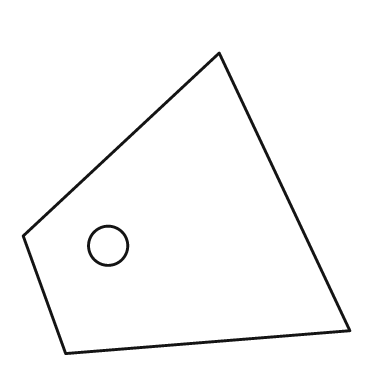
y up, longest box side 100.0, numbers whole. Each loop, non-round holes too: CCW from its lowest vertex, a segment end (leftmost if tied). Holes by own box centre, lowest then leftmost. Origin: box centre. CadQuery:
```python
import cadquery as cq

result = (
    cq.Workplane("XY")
    .moveTo(-37.0, -46.0)
    .lineTo(50.0, -39.0)
    .lineTo(10.0, 46.0)
    .lineTo(-50.0, -10.0)
    .close()
    .moveTo(-24.0, -13.0)
    .circle(6.0)
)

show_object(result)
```